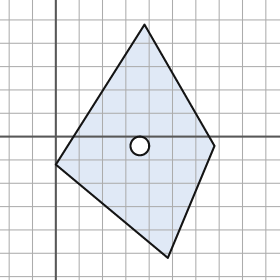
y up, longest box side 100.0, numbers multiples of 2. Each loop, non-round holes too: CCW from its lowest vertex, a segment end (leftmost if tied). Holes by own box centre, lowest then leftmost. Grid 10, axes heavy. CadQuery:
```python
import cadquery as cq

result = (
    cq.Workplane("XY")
    .moveTo(48.0, -52.0)
    .lineTo(68.0, -4.0)
    .lineTo(38.0, 48.0)
    .lineTo(0.0, -12.0)
    .close()
    .moveTo(36.0, -4.0)
    .circle(4.0)
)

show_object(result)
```